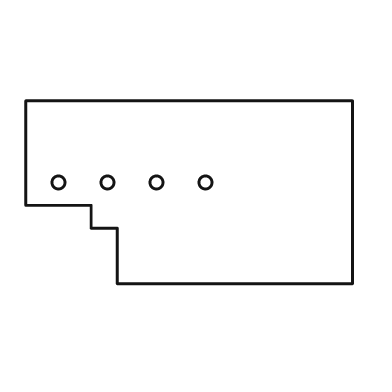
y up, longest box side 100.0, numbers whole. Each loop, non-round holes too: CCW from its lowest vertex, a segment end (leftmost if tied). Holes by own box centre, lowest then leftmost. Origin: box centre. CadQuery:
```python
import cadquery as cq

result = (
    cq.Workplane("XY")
    .moveTo(-22.0, -28.0)
    .lineTo(50.0, -28.0)
    .lineTo(50.0, 28.0)
    .lineTo(-50.0, 28.0)
    .lineTo(-50.0, -4.0)
    .lineTo(-30.0, -4.0)
    .lineTo(-30.0, -11.0)
    .lineTo(-22.0, -11.0)
    .close()
    .moveTo(-40.0, 3.0)
    .circle(2.0)
    .moveTo(-25.0, 3.0)
    .circle(2.0)
    .moveTo(-10.0, 3.0)
    .circle(2.0)
    .moveTo(5.0, 3.0)
    .circle(2.0)
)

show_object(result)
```